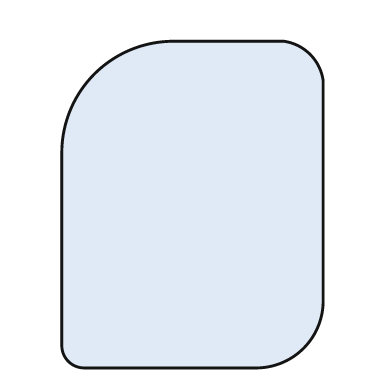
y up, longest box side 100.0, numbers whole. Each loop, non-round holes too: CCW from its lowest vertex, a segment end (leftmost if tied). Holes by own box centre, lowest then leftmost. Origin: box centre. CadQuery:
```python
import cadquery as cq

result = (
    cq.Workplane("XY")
    .moveTo(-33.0, -50.0)
    .lineTo(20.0, -50.0)
    .threePointArc((34.0, -44.0), (40.0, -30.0))
    .lineTo(40.0, 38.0)
    .threePointArc((36.0, 46.0), (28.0, 50.0))
    .lineTo(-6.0, 50.0)
    .threePointArc((-30.0, 40.0), (-40.0, 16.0))
    .lineTo(-40.0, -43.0)
    .threePointArc((-38.0, -48.0), (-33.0, -50.0))
    .close()
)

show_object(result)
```